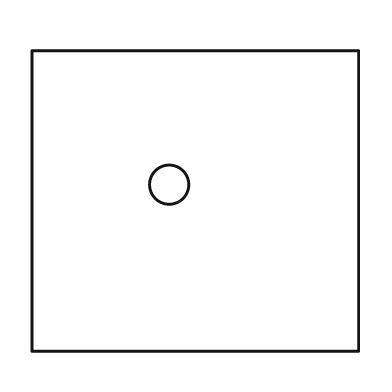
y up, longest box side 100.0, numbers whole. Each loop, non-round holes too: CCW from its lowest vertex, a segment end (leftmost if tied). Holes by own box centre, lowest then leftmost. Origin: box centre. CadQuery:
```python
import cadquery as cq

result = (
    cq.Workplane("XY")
    .moveTo(-50.0, -46.0)
    .lineTo(50.0, -46.0)
    .lineTo(50.0, 46.0)
    .lineTo(-50.0, 46.0)
    .close()
    .moveTo(-8.0, 5.0)
    .circle(6.0)
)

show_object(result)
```